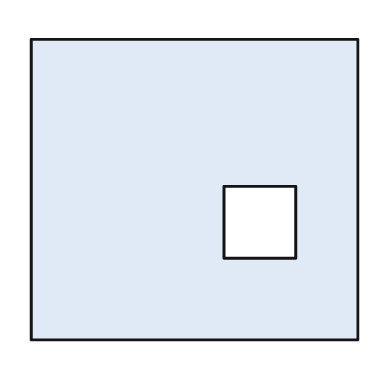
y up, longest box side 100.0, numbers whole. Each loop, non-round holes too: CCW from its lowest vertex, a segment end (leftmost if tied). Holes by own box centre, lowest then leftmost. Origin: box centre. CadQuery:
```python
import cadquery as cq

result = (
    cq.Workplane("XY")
    .moveTo(-50.0, -46.0)
    .lineTo(50.0, -46.0)
    .lineTo(50.0, 46.0)
    .lineTo(-50.0, 46.0)
    .close()
    .moveTo(9.0, -21.0)
    .lineTo(31.0, -21.0)
    .lineTo(31.0, 1.0)
    .lineTo(9.0, 1.0)
    .close()
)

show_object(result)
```